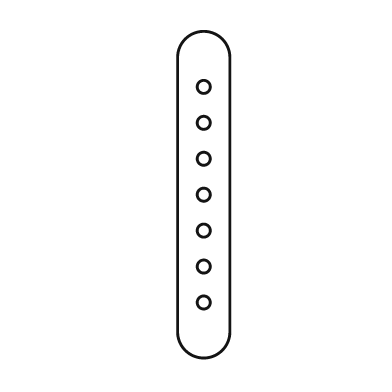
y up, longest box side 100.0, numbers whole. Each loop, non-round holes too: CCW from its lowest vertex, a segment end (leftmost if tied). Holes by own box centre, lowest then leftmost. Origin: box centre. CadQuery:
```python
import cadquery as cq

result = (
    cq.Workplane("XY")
    .moveTo(-8.0, -42.0)
    .threePointArc((0.0, -50.0), (8.0, -42.0))
    .lineTo(8.0, 42.0)
    .threePointArc((0.0, 50.0), (-8.0, 42.0))
    .close()
    .moveTo(0.0, -33.0)
    .circle(2.0)
    .moveTo(0.0, -22.0)
    .circle(2.0)
    .moveTo(0.0, -11.0)
    .circle(2.0)
    .moveTo(0.0, 0.0)
    .circle(2.0)
    .moveTo(0.0, 11.0)
    .circle(2.0)
    .moveTo(0.0, 22.0)
    .circle(2.0)
    .moveTo(0.0, 33.0)
    .circle(2.0)
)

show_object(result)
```